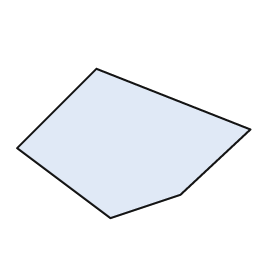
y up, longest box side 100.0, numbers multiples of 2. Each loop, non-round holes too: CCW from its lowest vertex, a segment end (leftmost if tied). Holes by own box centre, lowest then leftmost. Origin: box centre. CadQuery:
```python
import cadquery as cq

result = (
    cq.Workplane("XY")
    .moveTo(-10.0, -32.0)
    .lineTo(20.0, -22.0)
    .lineTo(50.0, 6.0)
    .lineTo(-16.0, 32.0)
    .lineTo(-50.0, -2.0)
    .close()
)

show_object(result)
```